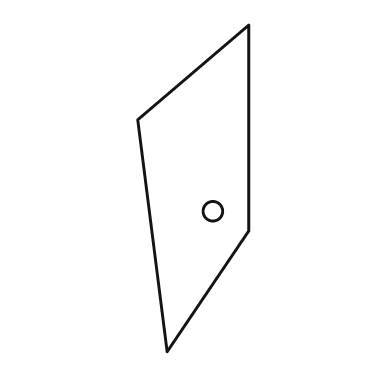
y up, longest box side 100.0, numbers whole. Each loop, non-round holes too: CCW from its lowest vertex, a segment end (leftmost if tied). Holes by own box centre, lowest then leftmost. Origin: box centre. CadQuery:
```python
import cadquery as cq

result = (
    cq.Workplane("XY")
    .moveTo(-8.0, -50.0)
    .lineTo(17.0, -13.0)
    .lineTo(17.0, 50.0)
    .lineTo(-17.0, 21.0)
    .close()
    .moveTo(6.0, -7.0)
    .circle(3.0)
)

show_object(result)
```